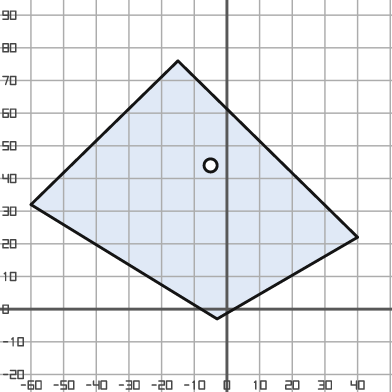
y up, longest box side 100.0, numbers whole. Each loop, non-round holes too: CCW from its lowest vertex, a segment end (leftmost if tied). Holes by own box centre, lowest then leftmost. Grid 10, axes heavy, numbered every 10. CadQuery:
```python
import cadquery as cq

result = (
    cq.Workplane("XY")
    .moveTo(-3.0, -3.0)
    .lineTo(40.0, 22.0)
    .lineTo(-15.0, 76.0)
    .lineTo(-60.0, 32.0)
    .close()
    .moveTo(-5.0, 44.0)
    .circle(2.0)
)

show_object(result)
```